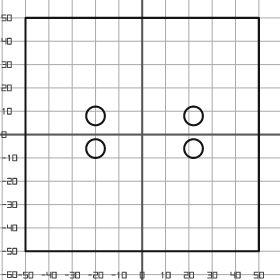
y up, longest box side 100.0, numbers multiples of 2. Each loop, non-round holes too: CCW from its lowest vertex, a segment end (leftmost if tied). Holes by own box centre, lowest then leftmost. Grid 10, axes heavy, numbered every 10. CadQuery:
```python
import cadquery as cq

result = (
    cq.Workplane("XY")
    .moveTo(-50.0, -50.0)
    .lineTo(50.0, -50.0)
    .lineTo(50.0, 50.0)
    .lineTo(-50.0, 50.0)
    .close()
    .moveTo(-20.0, -6.0)
    .circle(4.0)
    .moveTo(22.0, -6.0)
    .circle(4.0)
    .moveTo(-20.0, 8.0)
    .circle(4.0)
    .moveTo(22.0, 8.0)
    .circle(4.0)
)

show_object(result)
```